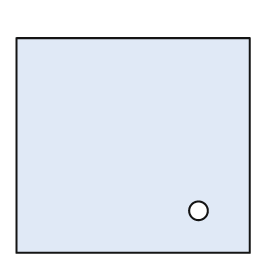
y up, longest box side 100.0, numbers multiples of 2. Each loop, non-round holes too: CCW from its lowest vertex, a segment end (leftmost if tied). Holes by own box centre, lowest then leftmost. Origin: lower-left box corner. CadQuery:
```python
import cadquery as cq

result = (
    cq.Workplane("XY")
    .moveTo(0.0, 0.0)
    .lineTo(100.0, 0.0)
    .lineTo(100.0, 92.0)
    .lineTo(0.0, 92.0)
    .close()
    .moveTo(78.0, 18.0)
    .circle(4.0)
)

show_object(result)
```